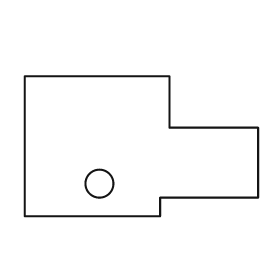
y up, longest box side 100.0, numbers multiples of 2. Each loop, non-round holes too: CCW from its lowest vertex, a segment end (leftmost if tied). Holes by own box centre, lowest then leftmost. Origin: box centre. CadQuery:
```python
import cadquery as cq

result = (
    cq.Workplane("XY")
    .moveTo(-50.0, -30.0)
    .lineTo(8.0, -30.0)
    .lineTo(8.0, -22.0)
    .lineTo(50.0, -22.0)
    .lineTo(50.0, 8.0)
    .lineTo(12.0, 8.0)
    .lineTo(12.0, 30.0)
    .lineTo(-50.0, 30.0)
    .close()
    .moveTo(-18.0, -16.0)
    .circle(6.0)
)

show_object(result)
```